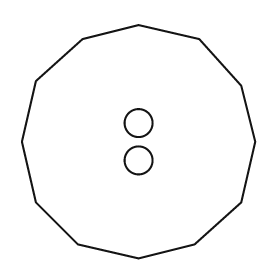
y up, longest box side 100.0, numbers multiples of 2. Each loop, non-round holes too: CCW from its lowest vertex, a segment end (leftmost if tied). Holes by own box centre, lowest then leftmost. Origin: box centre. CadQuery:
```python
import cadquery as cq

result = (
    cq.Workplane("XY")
    .moveTo(0.0, -50.0)
    .lineTo(24.0, -44.0)
    .lineTo(44.0, -26.0)
    .lineTo(50.0, 0.0)
    .lineTo(44.0, 24.0)
    .lineTo(26.0, 44.0)
    .lineTo(0.0, 50.0)
    .lineTo(-24.0, 44.0)
    .lineTo(-44.0, 26.0)
    .lineTo(-50.0, 0.0)
    .lineTo(-44.0, -26.0)
    .lineTo(-26.0, -44.0)
    .close()
    .moveTo(0.0, -8.0)
    .circle(6.0)
    .moveTo(0.0, 8.0)
    .circle(6.0)
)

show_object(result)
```